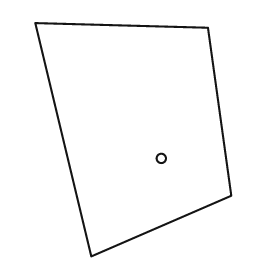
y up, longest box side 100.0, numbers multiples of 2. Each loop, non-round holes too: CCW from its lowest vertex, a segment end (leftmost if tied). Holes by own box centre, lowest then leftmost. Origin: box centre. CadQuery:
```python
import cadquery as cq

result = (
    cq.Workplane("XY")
    .moveTo(-18.0, -50.0)
    .lineTo(42.0, -24.0)
    .lineTo(32.0, 48.0)
    .lineTo(-42.0, 50.0)
    .close()
    .moveTo(12.0, -8.0)
    .circle(2.0)
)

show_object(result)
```